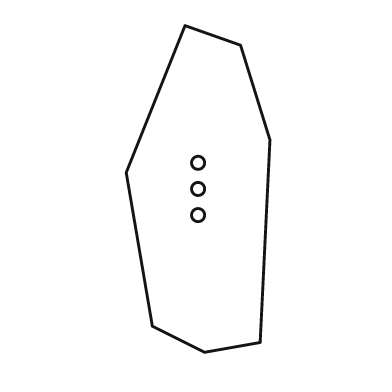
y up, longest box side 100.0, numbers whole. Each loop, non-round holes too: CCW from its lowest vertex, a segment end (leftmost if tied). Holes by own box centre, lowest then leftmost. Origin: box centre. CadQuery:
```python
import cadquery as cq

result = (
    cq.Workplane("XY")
    .moveTo(2.0, -50.0)
    .lineTo(19.0, -47.0)
    .lineTo(22.0, 15.0)
    .lineTo(13.0, 44.0)
    .lineTo(-4.0, 50.0)
    .lineTo(-22.0, 5.0)
    .lineTo(-14.0, -42.0)
    .close()
    .moveTo(0.0, -8.0)
    .circle(2.0)
    .moveTo(0.0, 0.0)
    .circle(2.0)
    .moveTo(0.0, 8.0)
    .circle(2.0)
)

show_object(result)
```